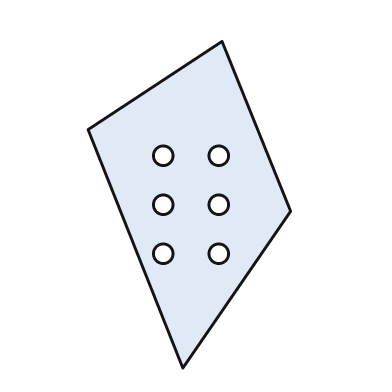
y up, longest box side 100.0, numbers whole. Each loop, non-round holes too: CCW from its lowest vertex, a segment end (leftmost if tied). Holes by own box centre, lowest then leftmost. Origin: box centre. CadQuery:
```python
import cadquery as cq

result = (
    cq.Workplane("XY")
    .moveTo(-2.0, -50.0)
    .lineTo(31.0, -2.0)
    .lineTo(10.0, 50.0)
    .lineTo(-31.0, 23.0)
    .close()
    .moveTo(-8.0, -15.0)
    .circle(3.0)
    .moveTo(9.0, -15.0)
    .circle(3.0)
    .moveTo(-8.0, 0.0)
    .circle(3.0)
    .moveTo(9.0, 0.0)
    .circle(3.0)
    .moveTo(-8.0, 15.0)
    .circle(3.0)
    .moveTo(9.0, 15.0)
    .circle(3.0)
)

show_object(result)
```